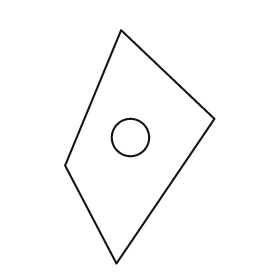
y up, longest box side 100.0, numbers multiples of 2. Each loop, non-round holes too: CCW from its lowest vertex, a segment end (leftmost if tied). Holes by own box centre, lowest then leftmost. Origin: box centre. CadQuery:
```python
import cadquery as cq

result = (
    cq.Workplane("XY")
    .moveTo(-10.0, -50.0)
    .lineTo(32.0, 12.0)
    .lineTo(-8.0, 50.0)
    .lineTo(-32.0, -8.0)
    .close()
    .moveTo(-4.0, 4.0)
    .circle(8.0)
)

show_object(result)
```